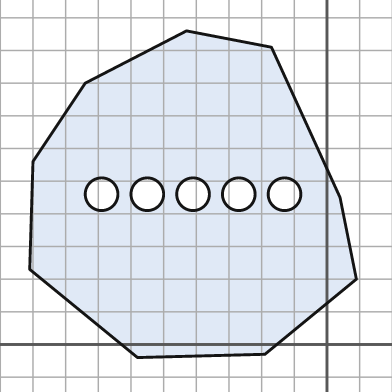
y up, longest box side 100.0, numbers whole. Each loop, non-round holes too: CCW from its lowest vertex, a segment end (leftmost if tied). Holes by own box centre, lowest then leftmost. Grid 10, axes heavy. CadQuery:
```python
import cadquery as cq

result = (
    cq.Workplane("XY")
    .moveTo(-58.0, -4.0)
    .lineTo(-19.0, -3.0)
    .lineTo(9.0, 20.0)
    .lineTo(4.0, 45.0)
    .lineTo(-17.0, 91.0)
    .lineTo(-43.0, 96.0)
    .lineTo(-74.0, 80.0)
    .lineTo(-90.0, 56.0)
    .lineTo(-91.0, 23.0)
    .close()
    .moveTo(-69.0, 46.0)
    .circle(5.0)
    .moveTo(-55.0, 46.0)
    .circle(5.0)
    .moveTo(-41.0, 46.0)
    .circle(5.0)
    .moveTo(-27.0, 46.0)
    .circle(5.0)
    .moveTo(-13.0, 46.0)
    .circle(5.0)
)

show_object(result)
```